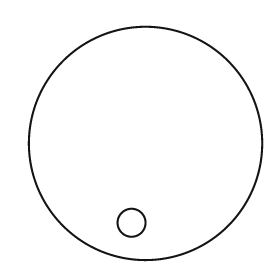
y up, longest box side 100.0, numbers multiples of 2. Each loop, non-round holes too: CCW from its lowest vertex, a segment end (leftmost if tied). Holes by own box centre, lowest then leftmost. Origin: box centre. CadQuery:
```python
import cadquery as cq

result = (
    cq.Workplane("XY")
    .moveTo(0.0, 0.0)
    .circle(50.0)
    .moveTo(-6.0, -34.0)
    .circle(6.0)
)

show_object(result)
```